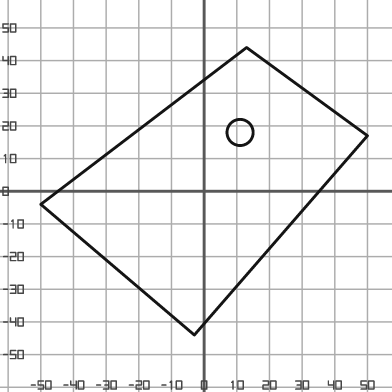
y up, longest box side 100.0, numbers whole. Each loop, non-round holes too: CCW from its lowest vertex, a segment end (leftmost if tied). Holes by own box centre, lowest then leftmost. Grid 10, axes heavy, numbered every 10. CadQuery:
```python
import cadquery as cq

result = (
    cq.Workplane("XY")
    .moveTo(-3.0, -44.0)
    .lineTo(50.0, 17.0)
    .lineTo(13.0, 44.0)
    .lineTo(-50.0, -4.0)
    .close()
    .moveTo(11.0, 18.0)
    .circle(4.0)
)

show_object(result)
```